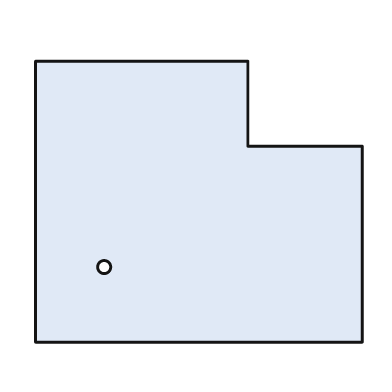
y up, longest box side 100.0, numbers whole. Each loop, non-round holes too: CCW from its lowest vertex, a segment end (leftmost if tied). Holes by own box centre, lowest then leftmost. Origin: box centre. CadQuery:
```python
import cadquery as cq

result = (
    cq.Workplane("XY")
    .moveTo(-50.0, -43.0)
    .lineTo(50.0, -43.0)
    .lineTo(50.0, 17.0)
    .lineTo(15.0, 17.0)
    .lineTo(15.0, 43.0)
    .lineTo(-50.0, 43.0)
    .close()
    .moveTo(-29.0, -20.0)
    .circle(2.0)
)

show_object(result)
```